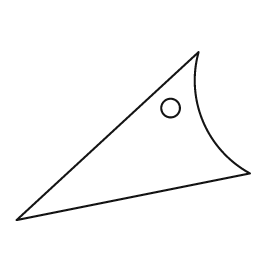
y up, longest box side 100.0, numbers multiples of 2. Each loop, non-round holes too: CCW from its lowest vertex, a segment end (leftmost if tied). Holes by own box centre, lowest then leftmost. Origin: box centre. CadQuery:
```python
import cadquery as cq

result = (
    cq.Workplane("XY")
    .moveTo(-50.0, -36.0)
    .lineTo(50.0, -16.0)
    .threePointArc((30.0, 6.0), (28.0, 36.0))
    .close()
    .moveTo(16.0, 12.0)
    .circle(4.0)
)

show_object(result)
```